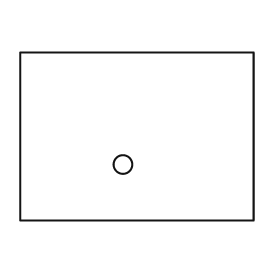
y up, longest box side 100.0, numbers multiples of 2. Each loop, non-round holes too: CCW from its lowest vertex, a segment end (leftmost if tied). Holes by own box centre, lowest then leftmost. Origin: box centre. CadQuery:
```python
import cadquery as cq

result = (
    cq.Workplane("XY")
    .moveTo(-50.0, -36.0)
    .lineTo(50.0, -36.0)
    .lineTo(50.0, 36.0)
    .lineTo(-50.0, 36.0)
    .close()
    .moveTo(-6.0, -12.0)
    .circle(4.0)
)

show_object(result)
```